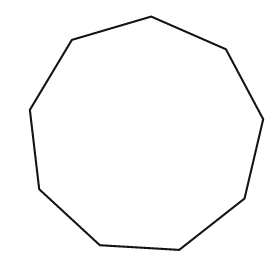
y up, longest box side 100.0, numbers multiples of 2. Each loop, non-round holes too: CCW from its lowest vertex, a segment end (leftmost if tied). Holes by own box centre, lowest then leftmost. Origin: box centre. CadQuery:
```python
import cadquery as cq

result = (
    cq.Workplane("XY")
    .moveTo(14.0, -50.0)
    .lineTo(42.0, -28.0)
    .lineTo(50.0, 6.0)
    .lineTo(34.0, 36.0)
    .lineTo(2.0, 50.0)
    .lineTo(-32.0, 40.0)
    .lineTo(-50.0, 10.0)
    .lineTo(-46.0, -24.0)
    .lineTo(-20.0, -48.0)
    .close()
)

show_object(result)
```